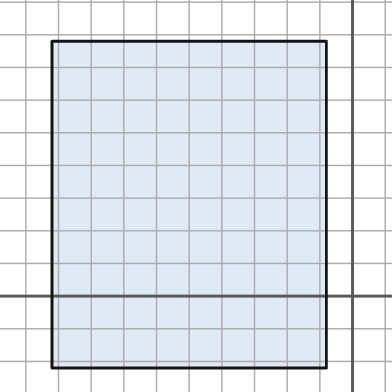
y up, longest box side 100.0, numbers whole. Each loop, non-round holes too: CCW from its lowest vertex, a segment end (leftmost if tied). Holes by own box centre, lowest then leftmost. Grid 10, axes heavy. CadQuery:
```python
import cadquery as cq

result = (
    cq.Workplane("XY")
    .moveTo(-92.0, -22.0)
    .lineTo(-8.0, -22.0)
    .lineTo(-8.0, 78.0)
    .lineTo(-92.0, 78.0)
    .close()
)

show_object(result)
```